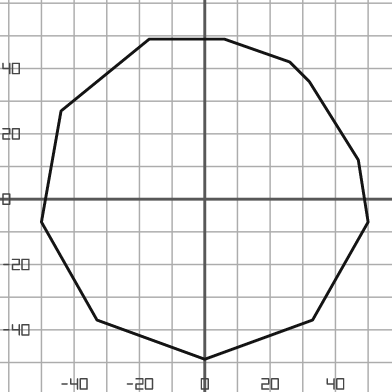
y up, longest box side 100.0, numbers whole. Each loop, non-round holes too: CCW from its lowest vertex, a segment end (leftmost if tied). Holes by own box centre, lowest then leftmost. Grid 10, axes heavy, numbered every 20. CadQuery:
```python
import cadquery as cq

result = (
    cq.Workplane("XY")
    .moveTo(0.0, -49.0)
    .lineTo(33.0, -37.0)
    .lineTo(50.0, -7.0)
    .lineTo(47.0, 12.0)
    .lineTo(32.0, 36.0)
    .lineTo(26.0, 42.0)
    .lineTo(6.0, 49.0)
    .lineTo(-17.0, 49.0)
    .lineTo(-44.0, 27.0)
    .lineTo(-50.0, -7.0)
    .lineTo(-33.0, -37.0)
    .close()
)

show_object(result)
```